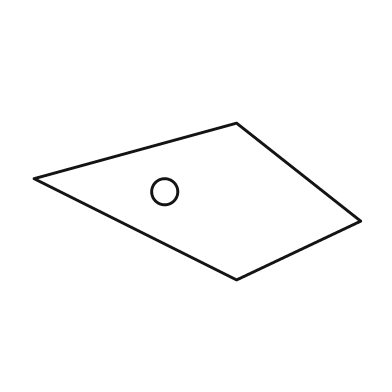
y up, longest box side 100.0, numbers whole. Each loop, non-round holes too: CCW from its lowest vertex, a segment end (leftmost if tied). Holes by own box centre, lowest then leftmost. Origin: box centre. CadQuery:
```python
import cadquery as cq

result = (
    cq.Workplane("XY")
    .moveTo(12.0, -24.0)
    .lineTo(50.0, -6.0)
    .lineTo(12.0, 24.0)
    .lineTo(-50.0, 7.0)
    .close()
    .moveTo(-10.0, 3.0)
    .circle(4.0)
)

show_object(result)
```